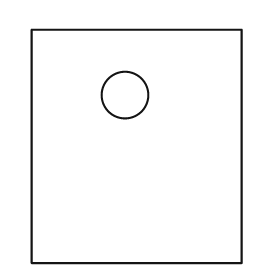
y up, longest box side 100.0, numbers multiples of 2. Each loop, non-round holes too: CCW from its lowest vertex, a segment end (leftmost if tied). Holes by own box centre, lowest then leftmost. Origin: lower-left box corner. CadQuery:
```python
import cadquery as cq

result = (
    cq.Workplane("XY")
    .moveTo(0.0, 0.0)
    .lineTo(90.0, 0.0)
    .lineTo(90.0, 100.0)
    .lineTo(0.0, 100.0)
    .close()
    .moveTo(40.0, 72.0)
    .circle(10.0)
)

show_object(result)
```